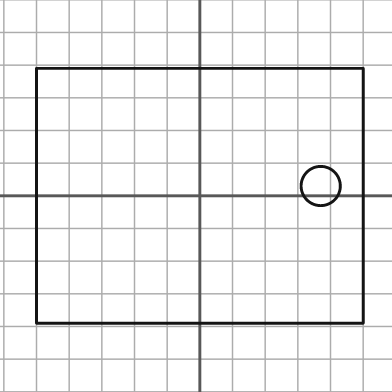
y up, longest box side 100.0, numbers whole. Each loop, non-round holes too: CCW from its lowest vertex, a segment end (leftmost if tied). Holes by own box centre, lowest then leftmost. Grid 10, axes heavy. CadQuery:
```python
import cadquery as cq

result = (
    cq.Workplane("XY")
    .moveTo(-50.0, -39.0)
    .lineTo(50.0, -39.0)
    .lineTo(50.0, 39.0)
    .lineTo(-50.0, 39.0)
    .close()
    .moveTo(37.0, 3.0)
    .circle(6.0)
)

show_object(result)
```